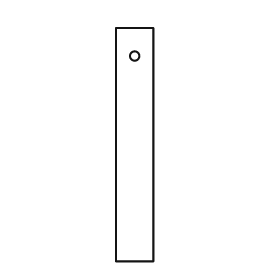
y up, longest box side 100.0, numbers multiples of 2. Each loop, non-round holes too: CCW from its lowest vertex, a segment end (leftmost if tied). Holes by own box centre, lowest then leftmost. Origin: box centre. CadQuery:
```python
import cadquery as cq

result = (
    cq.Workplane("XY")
    .moveTo(-8.0, -50.0)
    .lineTo(8.0, -50.0)
    .lineTo(8.0, 50.0)
    .lineTo(-8.0, 50.0)
    .close()
    .moveTo(0.0, 38.0)
    .circle(2.0)
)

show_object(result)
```